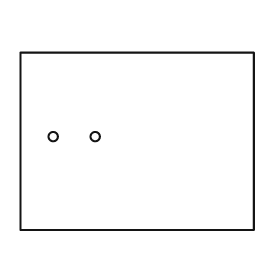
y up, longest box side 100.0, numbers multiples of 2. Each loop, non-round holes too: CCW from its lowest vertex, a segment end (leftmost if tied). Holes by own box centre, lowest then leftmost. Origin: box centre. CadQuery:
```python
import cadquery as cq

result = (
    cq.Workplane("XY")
    .moveTo(-50.0, -38.0)
    .lineTo(50.0, -38.0)
    .lineTo(50.0, 38.0)
    .lineTo(-50.0, 38.0)
    .close()
    .moveTo(-36.0, 2.0)
    .circle(2.0)
    .moveTo(-18.0, 2.0)
    .circle(2.0)
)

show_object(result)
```